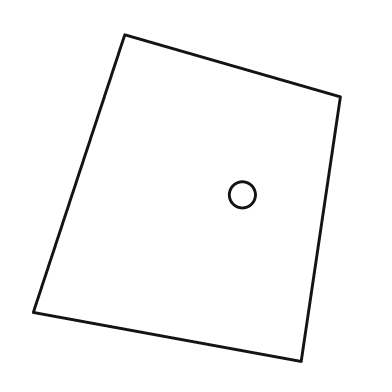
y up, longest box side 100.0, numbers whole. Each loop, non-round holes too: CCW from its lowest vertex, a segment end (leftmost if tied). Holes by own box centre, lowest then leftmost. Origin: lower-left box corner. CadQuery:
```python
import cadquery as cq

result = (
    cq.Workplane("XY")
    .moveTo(82.0, 0.0)
    .lineTo(94.0, 81.0)
    .lineTo(28.0, 100.0)
    .lineTo(0.0, 15.0)
    .close()
    .moveTo(64.0, 51.0)
    .circle(4.0)
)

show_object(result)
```